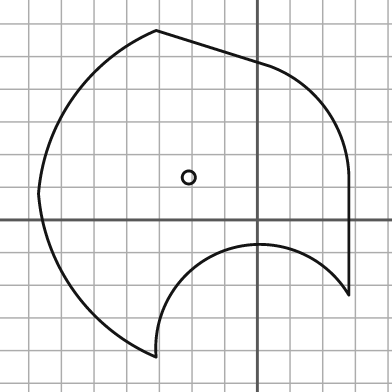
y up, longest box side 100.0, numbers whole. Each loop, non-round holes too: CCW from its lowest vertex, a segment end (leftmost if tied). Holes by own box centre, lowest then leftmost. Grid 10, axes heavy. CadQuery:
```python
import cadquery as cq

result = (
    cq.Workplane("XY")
    .moveTo(-31.0, -42.0)
    .threePointArc((-9.0, -9.0), (28.0, -23.0))
    .lineTo(28.0, 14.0)
    .threePointArc((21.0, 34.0), (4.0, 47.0))
    .lineTo(-31.0, 58.0)
    .threePointArc((-56.0, 38.0), (-67.0, 8.0))
    .threePointArc((-56.0, -22.0), (-31.0, -42.0))
    .close()
    .moveTo(-21.0, 13.0)
    .circle(2.0)
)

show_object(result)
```